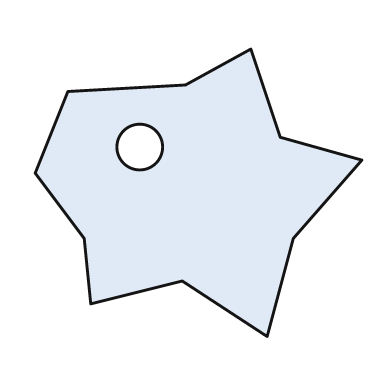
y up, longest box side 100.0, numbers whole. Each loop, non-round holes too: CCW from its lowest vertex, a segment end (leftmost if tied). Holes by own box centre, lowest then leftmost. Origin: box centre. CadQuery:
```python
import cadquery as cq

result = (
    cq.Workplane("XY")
    .moveTo(21.0, -44.0)
    .lineTo(29.0, -14.0)
    .lineTo(50.0, 10.0)
    .lineTo(25.0, 17.0)
    .lineTo(16.0, 44.0)
    .lineTo(-4.0, 33.0)
    .lineTo(-40.0, 31.0)
    .lineTo(-50.0, 6.0)
    .lineTo(-35.0, -14.0)
    .lineTo(-33.0, -34.0)
    .lineTo(-5.0, -27.0)
    .close()
    .moveTo(-18.0, 14.0)
    .circle(7.0)
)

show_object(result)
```